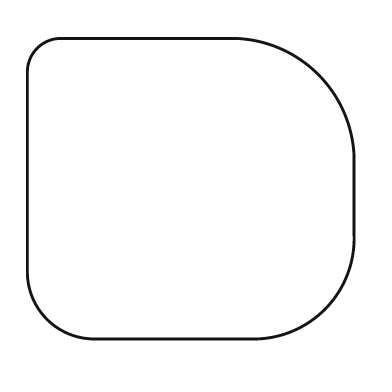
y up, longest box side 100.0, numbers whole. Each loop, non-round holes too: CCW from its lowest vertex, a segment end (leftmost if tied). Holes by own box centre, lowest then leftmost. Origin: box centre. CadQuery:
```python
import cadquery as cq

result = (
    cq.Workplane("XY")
    .moveTo(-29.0, -46.0)
    .lineTo(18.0, -46.0)
    .threePointArc((41.0, -37.0), (50.0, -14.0))
    .lineTo(50.0, 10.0)
    .threePointArc((39.0, 35.0), (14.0, 46.0))
    .lineTo(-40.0, 46.0)
    .threePointArc((-47.0, 43.0), (-50.0, 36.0))
    .lineTo(-50.0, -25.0)
    .threePointArc((-44.0, -40.0), (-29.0, -46.0))
    .close()
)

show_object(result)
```